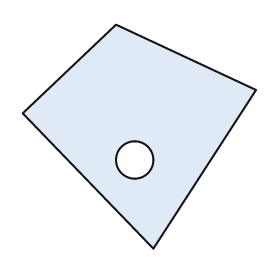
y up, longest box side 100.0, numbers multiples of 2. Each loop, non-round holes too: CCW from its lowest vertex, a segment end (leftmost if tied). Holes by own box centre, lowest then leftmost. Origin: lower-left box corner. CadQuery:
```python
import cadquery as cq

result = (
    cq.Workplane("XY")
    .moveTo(56.0, 0.0)
    .lineTo(100.0, 68.0)
    .lineTo(40.0, 96.0)
    .lineTo(0.0, 58.0)
    .close()
    .moveTo(48.0, 38.0)
    .circle(8.0)
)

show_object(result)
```